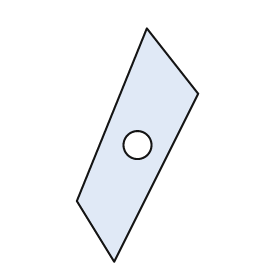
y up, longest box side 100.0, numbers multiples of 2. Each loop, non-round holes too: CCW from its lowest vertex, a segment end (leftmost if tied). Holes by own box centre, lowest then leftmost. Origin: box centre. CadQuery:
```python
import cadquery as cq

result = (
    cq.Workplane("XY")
    .moveTo(-10.0, -50.0)
    .lineTo(26.0, 22.0)
    .lineTo(4.0, 50.0)
    .lineTo(-26.0, -24.0)
    .close()
    .moveTo(0.0, 0.0)
    .circle(6.0)
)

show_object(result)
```